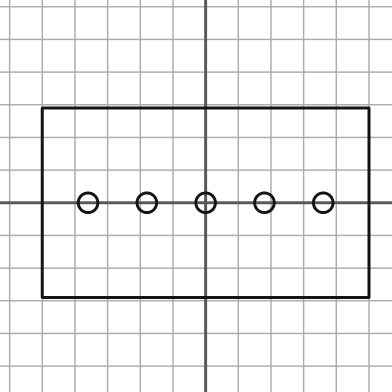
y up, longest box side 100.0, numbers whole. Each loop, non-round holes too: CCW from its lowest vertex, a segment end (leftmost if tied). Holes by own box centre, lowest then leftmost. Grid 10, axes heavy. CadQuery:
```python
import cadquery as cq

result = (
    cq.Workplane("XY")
    .moveTo(-50.0, -29.0)
    .lineTo(50.0, -29.0)
    .lineTo(50.0, 29.0)
    .lineTo(-50.0, 29.0)
    .close()
    .moveTo(-36.0, 0.0)
    .circle(3.0)
    .moveTo(-18.0, 0.0)
    .circle(3.0)
    .moveTo(0.0, 0.0)
    .circle(3.0)
    .moveTo(18.0, 0.0)
    .circle(3.0)
    .moveTo(36.0, 0.0)
    .circle(3.0)
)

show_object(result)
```